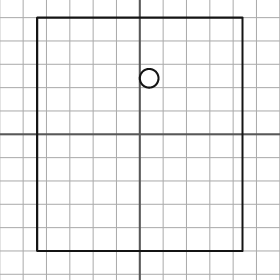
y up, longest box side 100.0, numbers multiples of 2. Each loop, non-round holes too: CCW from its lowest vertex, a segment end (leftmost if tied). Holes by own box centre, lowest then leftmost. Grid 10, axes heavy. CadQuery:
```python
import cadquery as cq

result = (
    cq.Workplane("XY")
    .moveTo(-44.0, -50.0)
    .lineTo(44.0, -50.0)
    .lineTo(44.0, 50.0)
    .lineTo(-44.0, 50.0)
    .close()
    .moveTo(4.0, 24.0)
    .circle(4.0)
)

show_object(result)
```